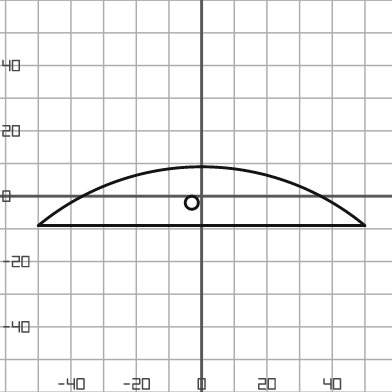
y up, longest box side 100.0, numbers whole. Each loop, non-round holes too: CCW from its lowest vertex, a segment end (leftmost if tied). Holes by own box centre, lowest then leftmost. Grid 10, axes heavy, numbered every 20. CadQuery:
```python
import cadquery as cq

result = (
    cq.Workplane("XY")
    .moveTo(-50.0, -9.0)
    .lineTo(50.0, -9.0)
    .threePointArc((0.0, 9.0), (-50.0, -9.0))
    .close()
    .moveTo(-3.0, -2.0)
    .circle(2.0)
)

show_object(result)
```